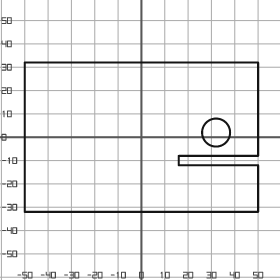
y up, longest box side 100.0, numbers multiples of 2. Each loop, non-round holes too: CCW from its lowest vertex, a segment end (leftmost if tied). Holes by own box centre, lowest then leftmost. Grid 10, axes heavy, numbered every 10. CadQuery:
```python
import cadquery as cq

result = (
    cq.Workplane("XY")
    .moveTo(-50.0, -32.0)
    .lineTo(50.0, -32.0)
    .lineTo(50.0, -12.0)
    .lineTo(16.0, -12.0)
    .lineTo(16.0, -8.0)
    .lineTo(50.0, -8.0)
    .lineTo(50.0, 32.0)
    .lineTo(-50.0, 32.0)
    .close()
    .moveTo(32.0, 2.0)
    .circle(6.0)
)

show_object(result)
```